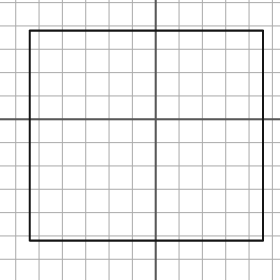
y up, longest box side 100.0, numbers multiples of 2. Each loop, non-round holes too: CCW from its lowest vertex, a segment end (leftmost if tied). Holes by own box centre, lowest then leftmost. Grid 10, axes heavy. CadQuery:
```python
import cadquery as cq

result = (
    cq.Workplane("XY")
    .moveTo(-54.0, -52.0)
    .lineTo(46.0, -52.0)
    .lineTo(46.0, 38.0)
    .lineTo(-54.0, 38.0)
    .close()
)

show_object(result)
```